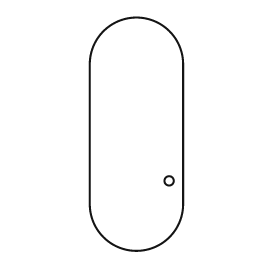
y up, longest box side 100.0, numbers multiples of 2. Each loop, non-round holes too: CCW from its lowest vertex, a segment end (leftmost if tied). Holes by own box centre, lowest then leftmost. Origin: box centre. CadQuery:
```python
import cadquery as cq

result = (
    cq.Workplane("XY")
    .moveTo(-20.0, -30.0)
    .threePointArc((0.0, -50.0), (20.0, -30.0))
    .lineTo(20.0, 30.0)
    .threePointArc((0.0, 50.0), (-20.0, 30.0))
    .close()
    .moveTo(14.0, -20.0)
    .circle(2.0)
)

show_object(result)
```